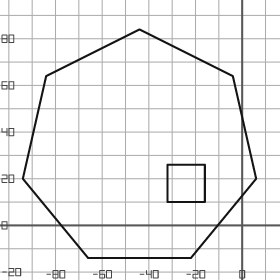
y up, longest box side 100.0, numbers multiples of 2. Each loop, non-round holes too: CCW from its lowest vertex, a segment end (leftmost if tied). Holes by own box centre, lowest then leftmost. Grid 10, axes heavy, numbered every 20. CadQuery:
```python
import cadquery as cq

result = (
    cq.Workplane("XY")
    .moveTo(-66.0, -14.0)
    .lineTo(-22.0, -14.0)
    .lineTo(6.0, 20.0)
    .lineTo(-4.0, 64.0)
    .lineTo(-44.0, 84.0)
    .lineTo(-84.0, 64.0)
    .lineTo(-94.0, 20.0)
    .close()
    .moveTo(-32.0, 10.0)
    .lineTo(-16.0, 10.0)
    .lineTo(-16.0, 26.0)
    .lineTo(-32.0, 26.0)
    .close()
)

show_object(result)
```